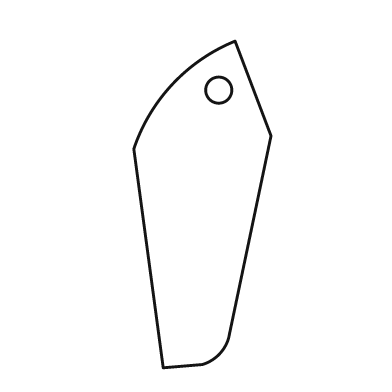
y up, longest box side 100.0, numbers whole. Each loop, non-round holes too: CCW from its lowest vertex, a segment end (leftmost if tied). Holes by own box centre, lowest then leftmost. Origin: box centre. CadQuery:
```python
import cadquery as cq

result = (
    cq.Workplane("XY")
    .moveTo(-12.0, -50.0)
    .lineTo(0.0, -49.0)
    .threePointArc((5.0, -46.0), (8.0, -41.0))
    .lineTo(21.0, 21.0)
    .lineTo(10.0, 50.0)
    .threePointArc((-9.0, 37.0), (-21.0, 17.0))
    .close()
    .moveTo(5.0, 35.0)
    .circle(4.0)
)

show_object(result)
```